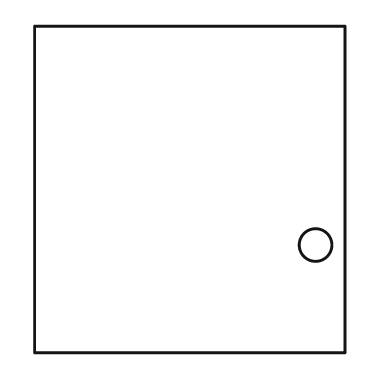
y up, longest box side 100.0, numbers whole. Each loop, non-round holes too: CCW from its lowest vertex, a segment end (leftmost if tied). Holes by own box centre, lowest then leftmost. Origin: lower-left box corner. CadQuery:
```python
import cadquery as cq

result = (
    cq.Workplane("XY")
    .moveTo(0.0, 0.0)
    .lineTo(95.0, 0.0)
    .lineTo(95.0, 100.0)
    .lineTo(0.0, 100.0)
    .close()
    .moveTo(86.0, 33.0)
    .circle(5.0)
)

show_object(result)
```